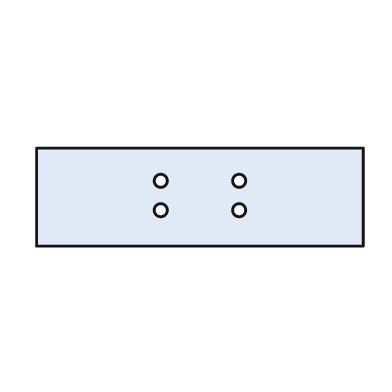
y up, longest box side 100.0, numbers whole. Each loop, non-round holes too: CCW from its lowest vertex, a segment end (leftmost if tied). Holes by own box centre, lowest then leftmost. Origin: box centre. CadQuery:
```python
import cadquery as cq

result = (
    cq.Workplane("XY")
    .moveTo(-50.0, -15.0)
    .lineTo(50.0, -15.0)
    .lineTo(50.0, 15.0)
    .lineTo(-50.0, 15.0)
    .close()
    .moveTo(-12.0, -4.0)
    .circle(2.0)
    .moveTo(12.0, -4.0)
    .circle(2.0)
    .moveTo(-12.0, 5.0)
    .circle(2.0)
    .moveTo(12.0, 5.0)
    .circle(2.0)
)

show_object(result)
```